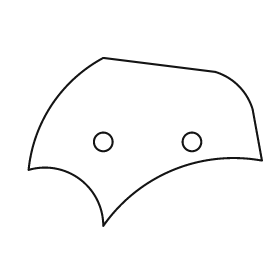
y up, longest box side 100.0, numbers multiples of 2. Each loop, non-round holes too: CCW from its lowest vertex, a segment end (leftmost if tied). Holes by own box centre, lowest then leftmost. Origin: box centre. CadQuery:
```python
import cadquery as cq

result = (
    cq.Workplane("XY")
    .moveTo(-18.0, -36.0)
    .threePointArc((12.0, -12.0), (50.0, -8.0))
    .lineTo(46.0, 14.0)
    .threePointArc((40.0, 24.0), (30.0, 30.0))
    .lineTo(-18.0, 36.0)
    .threePointArc((-40.0, 16.0), (-50.0, -12.0))
    .threePointArc((-28.0, -16.0), (-18.0, -36.0))
    .close()
    .moveTo(-18.0, 0.0)
    .circle(4.0)
    .moveTo(20.0, 0.0)
    .circle(4.0)
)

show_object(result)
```